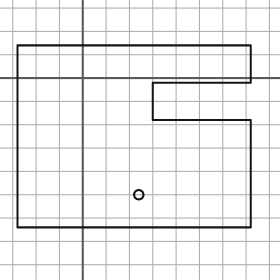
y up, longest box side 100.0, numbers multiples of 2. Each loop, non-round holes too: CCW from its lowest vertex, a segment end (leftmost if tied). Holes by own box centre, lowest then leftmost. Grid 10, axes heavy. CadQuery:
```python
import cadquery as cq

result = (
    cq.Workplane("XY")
    .moveTo(-28.0, -64.0)
    .lineTo(72.0, -64.0)
    .lineTo(72.0, -18.0)
    .lineTo(30.0, -18.0)
    .lineTo(30.0, -2.0)
    .lineTo(72.0, -2.0)
    .lineTo(72.0, 14.0)
    .lineTo(-28.0, 14.0)
    .close()
    .moveTo(24.0, -50.0)
    .circle(2.0)
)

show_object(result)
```